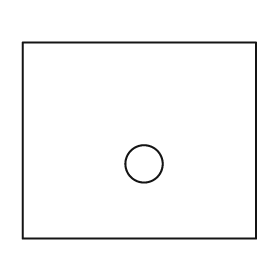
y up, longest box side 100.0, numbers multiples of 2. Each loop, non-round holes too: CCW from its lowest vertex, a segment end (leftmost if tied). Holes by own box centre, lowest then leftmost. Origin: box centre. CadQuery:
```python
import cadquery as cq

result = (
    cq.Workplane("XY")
    .moveTo(-50.0, -42.0)
    .lineTo(50.0, -42.0)
    .lineTo(50.0, 42.0)
    .lineTo(-50.0, 42.0)
    .close()
    .moveTo(2.0, -10.0)
    .circle(8.0)
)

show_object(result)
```